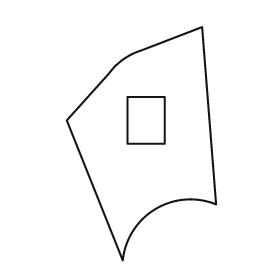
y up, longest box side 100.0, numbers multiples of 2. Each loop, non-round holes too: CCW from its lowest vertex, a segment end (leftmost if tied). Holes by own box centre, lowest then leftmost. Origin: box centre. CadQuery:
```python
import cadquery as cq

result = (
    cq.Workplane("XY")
    .moveTo(-8.0, -50.0)
    .threePointArc((6.0, -28.0), (32.0, -26.0))
    .lineTo(26.0, 50.0)
    .lineTo(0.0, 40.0)
    .threePointArc((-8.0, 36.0), (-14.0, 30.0))
    .lineTo(-32.0, 10.0)
    .close()
    .moveTo(-6.0, 0.0)
    .lineTo(10.0, 0.0)
    .lineTo(10.0, 20.0)
    .lineTo(-6.0, 20.0)
    .close()
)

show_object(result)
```